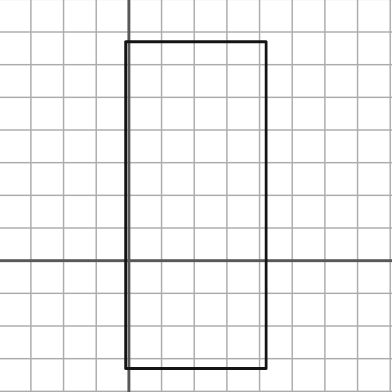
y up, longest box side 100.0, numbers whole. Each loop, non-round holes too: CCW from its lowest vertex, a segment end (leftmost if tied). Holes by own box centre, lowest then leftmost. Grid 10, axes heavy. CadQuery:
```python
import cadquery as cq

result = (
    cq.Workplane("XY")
    .moveTo(-1.0, -33.0)
    .lineTo(42.0, -33.0)
    .lineTo(42.0, 67.0)
    .lineTo(-1.0, 67.0)
    .close()
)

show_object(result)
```